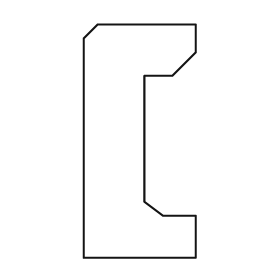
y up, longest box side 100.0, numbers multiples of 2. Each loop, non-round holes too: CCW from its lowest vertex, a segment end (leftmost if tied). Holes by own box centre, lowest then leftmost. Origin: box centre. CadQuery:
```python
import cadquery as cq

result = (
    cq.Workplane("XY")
    .moveTo(-24.0, -50.0)
    .lineTo(24.0, -50.0)
    .lineTo(24.0, -32.0)
    .lineTo(10.0, -32.0)
    .lineTo(2.0, -26.0)
    .lineTo(2.0, 28.0)
    .lineTo(14.0, 28.0)
    .lineTo(24.0, 38.0)
    .lineTo(24.0, 50.0)
    .lineTo(-18.0, 50.0)
    .lineTo(-24.0, 44.0)
    .close()
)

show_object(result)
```